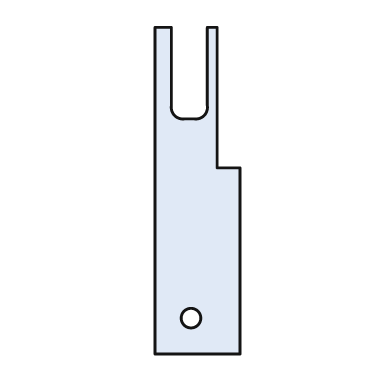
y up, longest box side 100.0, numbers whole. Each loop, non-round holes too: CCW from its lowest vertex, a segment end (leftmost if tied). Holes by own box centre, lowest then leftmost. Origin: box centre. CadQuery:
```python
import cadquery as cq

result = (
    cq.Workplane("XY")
    .moveTo(-13.0, -50.0)
    .lineTo(13.0, -50.0)
    .lineTo(13.0, 7.0)
    .lineTo(6.0, 7.0)
    .lineTo(6.0, 50.0)
    .lineTo(3.0, 50.0)
    .lineTo(3.0, 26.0)
    .threePointArc((2.0, 23.0), (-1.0, 22.0))
    .lineTo(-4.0, 22.0)
    .threePointArc((-7.0, 23.0), (-8.0, 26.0))
    .lineTo(-8.0, 50.0)
    .lineTo(-13.0, 50.0)
    .close()
    .moveTo(-2.0, -39.0)
    .circle(3.0)
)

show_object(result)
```